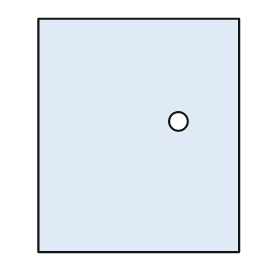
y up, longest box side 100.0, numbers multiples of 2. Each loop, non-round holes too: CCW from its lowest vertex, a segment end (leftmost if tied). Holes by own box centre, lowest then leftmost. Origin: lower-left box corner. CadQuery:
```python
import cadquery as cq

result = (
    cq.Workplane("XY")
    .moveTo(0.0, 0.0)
    .lineTo(86.0, 0.0)
    .lineTo(86.0, 100.0)
    .lineTo(0.0, 100.0)
    .close()
    .moveTo(60.0, 56.0)
    .circle(4.0)
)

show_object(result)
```